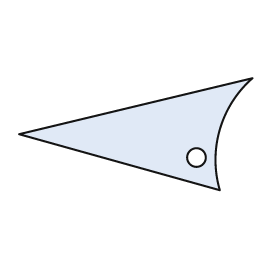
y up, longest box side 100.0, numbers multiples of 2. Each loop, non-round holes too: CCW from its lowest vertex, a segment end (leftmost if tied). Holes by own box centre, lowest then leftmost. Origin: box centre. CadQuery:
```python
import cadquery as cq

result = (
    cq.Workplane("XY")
    .moveTo(36.0, -24.0)
    .threePointArc((36.0, 2.0), (50.0, 24.0))
    .lineTo(-50.0, 0.0)
    .close()
    .moveTo(26.0, -10.0)
    .circle(4.0)
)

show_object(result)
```